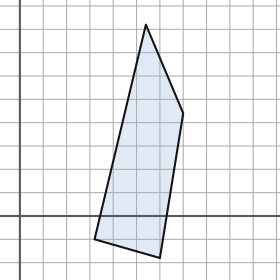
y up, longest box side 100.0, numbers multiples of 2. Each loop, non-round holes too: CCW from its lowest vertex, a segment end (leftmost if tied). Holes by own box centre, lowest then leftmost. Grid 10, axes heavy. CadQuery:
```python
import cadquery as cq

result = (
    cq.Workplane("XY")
    .moveTo(60.0, -18.0)
    .lineTo(70.0, 44.0)
    .lineTo(54.0, 82.0)
    .lineTo(32.0, -10.0)
    .close()
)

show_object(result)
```